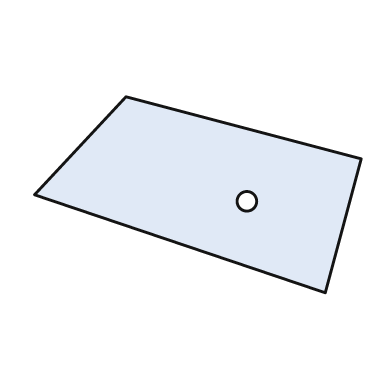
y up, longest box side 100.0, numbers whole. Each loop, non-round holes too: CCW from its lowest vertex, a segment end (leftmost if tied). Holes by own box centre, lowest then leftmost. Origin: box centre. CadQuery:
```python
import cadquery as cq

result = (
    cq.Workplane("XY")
    .moveTo(39.0, -30.0)
    .lineTo(50.0, 11.0)
    .lineTo(-22.0, 30.0)
    .lineTo(-50.0, 0.0)
    .close()
    .moveTo(15.0, -2.0)
    .circle(3.0)
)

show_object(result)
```